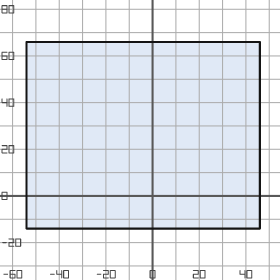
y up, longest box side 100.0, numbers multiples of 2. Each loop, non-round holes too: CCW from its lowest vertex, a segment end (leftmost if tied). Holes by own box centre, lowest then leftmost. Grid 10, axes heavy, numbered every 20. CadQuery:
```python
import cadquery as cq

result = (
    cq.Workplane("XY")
    .moveTo(-54.0, -14.0)
    .lineTo(46.0, -14.0)
    .lineTo(46.0, 66.0)
    .lineTo(-54.0, 66.0)
    .close()
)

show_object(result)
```